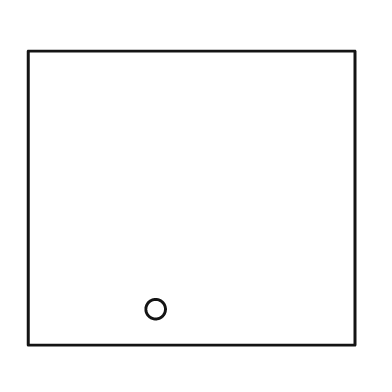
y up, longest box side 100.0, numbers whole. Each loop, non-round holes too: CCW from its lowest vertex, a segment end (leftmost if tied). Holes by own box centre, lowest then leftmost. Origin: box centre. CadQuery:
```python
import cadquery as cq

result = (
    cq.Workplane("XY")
    .moveTo(-50.0, -45.0)
    .lineTo(50.0, -45.0)
    .lineTo(50.0, 45.0)
    .lineTo(-50.0, 45.0)
    .close()
    .moveTo(-11.0, -34.0)
    .circle(3.0)
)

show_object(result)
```